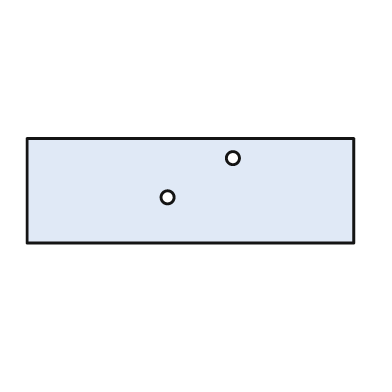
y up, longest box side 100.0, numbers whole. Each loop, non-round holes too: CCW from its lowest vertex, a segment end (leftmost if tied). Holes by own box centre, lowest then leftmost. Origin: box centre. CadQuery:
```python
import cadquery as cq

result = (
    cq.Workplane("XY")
    .moveTo(-50.0, -16.0)
    .lineTo(50.0, -16.0)
    .lineTo(50.0, 16.0)
    .lineTo(-50.0, 16.0)
    .close()
    .moveTo(-7.0, -2.0)
    .circle(2.0)
    .moveTo(13.0, 10.0)
    .circle(2.0)
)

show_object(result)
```